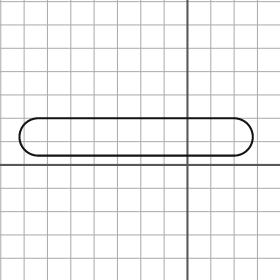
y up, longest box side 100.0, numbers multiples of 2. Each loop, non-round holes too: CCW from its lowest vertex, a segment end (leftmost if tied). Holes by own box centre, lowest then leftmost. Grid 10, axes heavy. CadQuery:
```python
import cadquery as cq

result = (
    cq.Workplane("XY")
    .moveTo(-64.0, 4.0)
    .lineTo(20.0, 4.0)
    .threePointArc((28.0, 12.0), (20.0, 20.0))
    .lineTo(-64.0, 20.0)
    .threePointArc((-72.0, 12.0), (-64.0, 4.0))
    .close()
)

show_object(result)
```